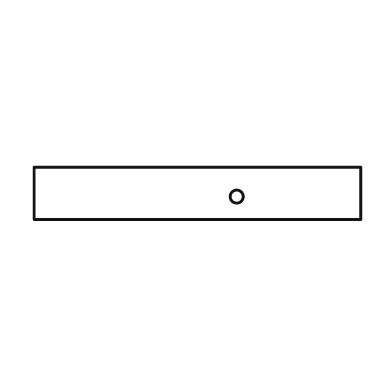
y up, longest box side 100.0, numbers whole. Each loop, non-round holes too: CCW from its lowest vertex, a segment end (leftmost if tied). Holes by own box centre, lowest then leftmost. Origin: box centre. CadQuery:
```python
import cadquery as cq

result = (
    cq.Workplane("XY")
    .moveTo(-50.0, -8.0)
    .lineTo(50.0, -8.0)
    .lineTo(50.0, 8.0)
    .lineTo(-50.0, 8.0)
    .close()
    .moveTo(12.0, -1.0)
    .circle(2.0)
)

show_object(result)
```